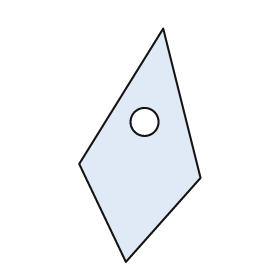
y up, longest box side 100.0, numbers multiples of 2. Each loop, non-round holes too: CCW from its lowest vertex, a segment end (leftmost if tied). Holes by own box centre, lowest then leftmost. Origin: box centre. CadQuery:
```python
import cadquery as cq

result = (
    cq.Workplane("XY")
    .moveTo(-6.0, -50.0)
    .lineTo(26.0, -14.0)
    .lineTo(10.0, 50.0)
    .lineTo(-26.0, -8.0)
    .close()
    .moveTo(2.0, 10.0)
    .circle(6.0)
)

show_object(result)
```